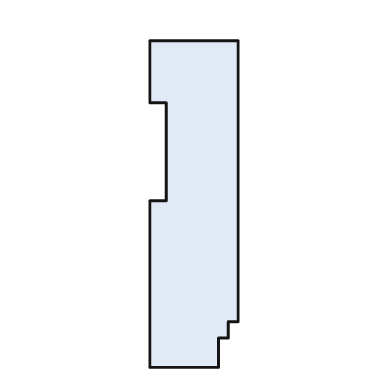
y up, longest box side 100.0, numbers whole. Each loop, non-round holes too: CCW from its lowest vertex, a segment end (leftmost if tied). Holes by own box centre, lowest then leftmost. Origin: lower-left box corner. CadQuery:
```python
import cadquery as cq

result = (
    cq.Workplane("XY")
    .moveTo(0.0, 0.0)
    .lineTo(21.0, 0.0)
    .lineTo(21.0, 9.0)
    .lineTo(24.0, 9.0)
    .lineTo(24.0, 14.0)
    .lineTo(27.0, 14.0)
    .lineTo(27.0, 100.0)
    .lineTo(0.0, 100.0)
    .lineTo(0.0, 81.0)
    .lineTo(5.0, 81.0)
    .lineTo(5.0, 51.0)
    .lineTo(0.0, 51.0)
    .close()
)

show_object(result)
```